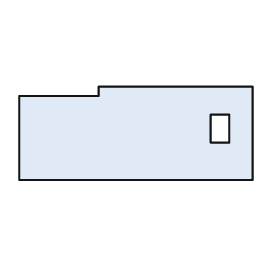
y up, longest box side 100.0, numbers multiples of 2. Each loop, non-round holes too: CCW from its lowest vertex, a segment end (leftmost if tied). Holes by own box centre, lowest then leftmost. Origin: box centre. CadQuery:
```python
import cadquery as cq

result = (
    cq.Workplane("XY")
    .moveTo(-50.0, -20.0)
    .lineTo(50.0, -20.0)
    .lineTo(50.0, 20.0)
    .lineTo(-16.0, 20.0)
    .lineTo(-16.0, 16.0)
    .lineTo(-50.0, 16.0)
    .close()
    .moveTo(32.0, -4.0)
    .lineTo(40.0, -4.0)
    .lineTo(40.0, 8.0)
    .lineTo(32.0, 8.0)
    .close()
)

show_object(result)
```